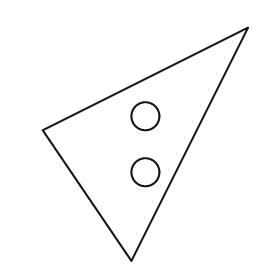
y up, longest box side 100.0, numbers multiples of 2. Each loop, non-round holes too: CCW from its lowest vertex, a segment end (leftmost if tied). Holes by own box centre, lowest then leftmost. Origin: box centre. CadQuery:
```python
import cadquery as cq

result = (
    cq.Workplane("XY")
    .moveTo(-6.0, -50.0)
    .lineTo(44.0, 50.0)
    .lineTo(-44.0, 6.0)
    .close()
    .moveTo(0.0, -12.0)
    .circle(6.0)
    .moveTo(0.0, 12.0)
    .circle(6.0)
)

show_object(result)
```